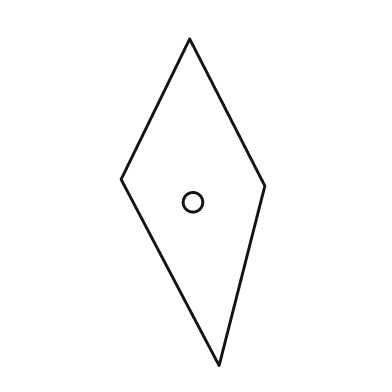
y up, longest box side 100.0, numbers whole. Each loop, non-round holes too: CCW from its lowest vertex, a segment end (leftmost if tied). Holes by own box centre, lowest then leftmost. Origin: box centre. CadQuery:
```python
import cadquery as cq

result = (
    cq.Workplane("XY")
    .moveTo(8.0, -50.0)
    .lineTo(22.0, 5.0)
    .lineTo(-1.0, 50.0)
    .lineTo(-22.0, 7.0)
    .close()
    .moveTo(0.0, 0.0)
    .circle(3.0)
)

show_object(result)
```